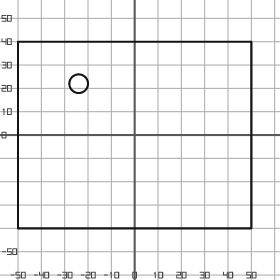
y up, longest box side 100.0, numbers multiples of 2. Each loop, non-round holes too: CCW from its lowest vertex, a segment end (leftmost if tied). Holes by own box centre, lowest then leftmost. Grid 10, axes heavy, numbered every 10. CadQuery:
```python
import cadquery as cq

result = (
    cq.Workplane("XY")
    .moveTo(-50.0, -40.0)
    .lineTo(50.0, -40.0)
    .lineTo(50.0, 40.0)
    .lineTo(-50.0, 40.0)
    .close()
    .moveTo(-24.0, 22.0)
    .circle(4.0)
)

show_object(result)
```